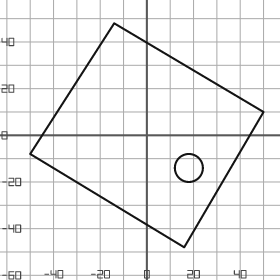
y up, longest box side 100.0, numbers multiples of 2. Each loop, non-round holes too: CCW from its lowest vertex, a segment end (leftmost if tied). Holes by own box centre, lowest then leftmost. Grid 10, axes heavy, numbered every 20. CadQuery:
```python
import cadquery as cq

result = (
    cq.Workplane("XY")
    .moveTo(16.0, -48.0)
    .lineTo(50.0, 10.0)
    .lineTo(-14.0, 48.0)
    .lineTo(-50.0, -8.0)
    .close()
    .moveTo(18.0, -14.0)
    .circle(6.0)
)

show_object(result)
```